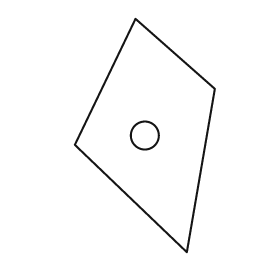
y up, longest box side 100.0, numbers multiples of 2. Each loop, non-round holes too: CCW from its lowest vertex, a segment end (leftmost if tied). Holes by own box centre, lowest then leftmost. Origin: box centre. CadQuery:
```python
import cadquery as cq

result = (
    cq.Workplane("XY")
    .moveTo(18.0, -50.0)
    .lineTo(30.0, 20.0)
    .lineTo(-4.0, 50.0)
    .lineTo(-30.0, -4.0)
    .close()
    .moveTo(0.0, 0.0)
    .circle(6.0)
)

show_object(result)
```